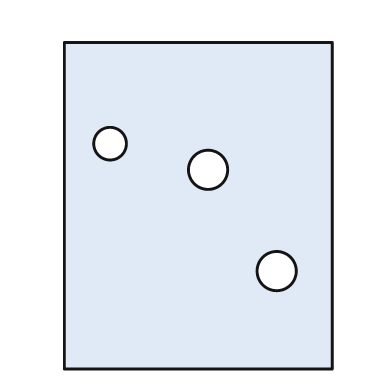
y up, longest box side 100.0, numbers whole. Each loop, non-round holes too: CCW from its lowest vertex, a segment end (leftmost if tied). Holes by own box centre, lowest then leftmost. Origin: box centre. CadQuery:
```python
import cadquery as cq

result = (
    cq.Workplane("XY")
    .moveTo(-41.0, -50.0)
    .lineTo(41.0, -50.0)
    .lineTo(41.0, 50.0)
    .lineTo(-41.0, 50.0)
    .close()
    .moveTo(24.0, -20.0)
    .circle(6.0)
    .moveTo(3.0, 11.0)
    .circle(6.0)
    .moveTo(-27.0, 19.0)
    .circle(5.0)
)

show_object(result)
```